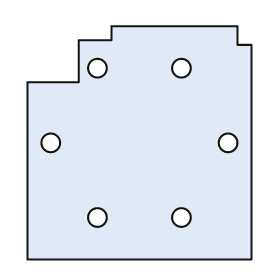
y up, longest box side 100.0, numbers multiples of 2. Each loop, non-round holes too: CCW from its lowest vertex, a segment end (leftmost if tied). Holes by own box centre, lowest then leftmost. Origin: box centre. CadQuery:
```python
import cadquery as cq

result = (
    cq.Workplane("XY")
    .moveTo(-48.0, -50.0)
    .lineTo(48.0, -50.0)
    .lineTo(48.0, 42.0)
    .lineTo(42.0, 42.0)
    .lineTo(42.0, 50.0)
    .lineTo(-12.0, 50.0)
    .lineTo(-12.0, 44.0)
    .lineTo(-26.0, 44.0)
    .lineTo(-26.0, 26.0)
    .lineTo(-48.0, 26.0)
    .close()
    .moveTo(-18.0, -32.0)
    .circle(4.0)
    .moveTo(18.0, -32.0)
    .circle(4.0)
    .moveTo(-38.0, 0.0)
    .circle(4.0)
    .moveTo(38.0, 0.0)
    .circle(4.0)
    .moveTo(-18.0, 32.0)
    .circle(4.0)
    .moveTo(18.0, 32.0)
    .circle(4.0)
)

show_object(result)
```